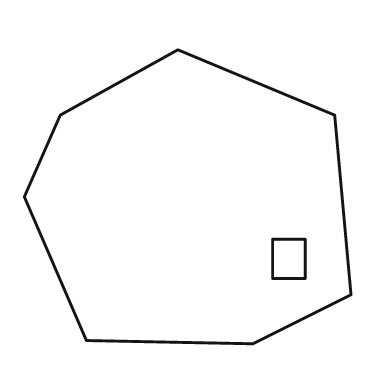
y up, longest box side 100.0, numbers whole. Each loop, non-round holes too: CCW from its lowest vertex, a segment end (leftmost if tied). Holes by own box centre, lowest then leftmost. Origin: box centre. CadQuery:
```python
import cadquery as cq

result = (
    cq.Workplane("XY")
    .moveTo(20.0, -45.0)
    .lineTo(50.0, -30.0)
    .lineTo(45.0, 25.0)
    .lineTo(-3.0, 45.0)
    .lineTo(-39.0, 25.0)
    .lineTo(-50.0, 0.0)
    .lineTo(-31.0, -44.0)
    .close()
    .moveTo(26.0, -25.0)
    .lineTo(36.0, -25.0)
    .lineTo(36.0, -13.0)
    .lineTo(26.0, -13.0)
    .close()
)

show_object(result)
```